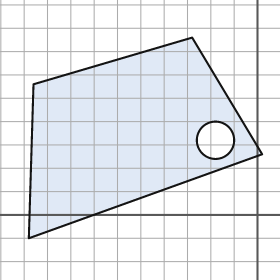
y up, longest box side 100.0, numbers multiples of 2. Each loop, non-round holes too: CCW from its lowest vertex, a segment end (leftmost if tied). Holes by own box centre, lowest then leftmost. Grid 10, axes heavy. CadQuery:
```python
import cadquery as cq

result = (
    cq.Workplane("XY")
    .moveTo(-98.0, -10.0)
    .lineTo(2.0, 26.0)
    .lineTo(-28.0, 76.0)
    .lineTo(-96.0, 56.0)
    .close()
    .moveTo(-18.0, 32.0)
    .circle(8.0)
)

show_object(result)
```